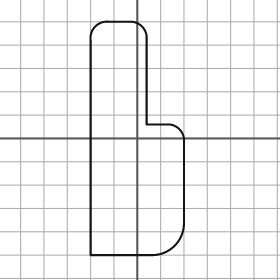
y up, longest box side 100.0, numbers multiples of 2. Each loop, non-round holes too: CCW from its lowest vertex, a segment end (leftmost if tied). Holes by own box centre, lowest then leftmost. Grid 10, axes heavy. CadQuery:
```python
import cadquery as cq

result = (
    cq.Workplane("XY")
    .moveTo(-20.0, -50.0)
    .lineTo(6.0, -50.0)
    .threePointArc((16.0, -46.0), (20.0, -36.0))
    .lineTo(20.0, 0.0)
    .threePointArc((18.0, 4.0), (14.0, 6.0))
    .lineTo(4.0, 6.0)
    .lineTo(4.0, 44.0)
    .threePointArc((2.0, 48.0), (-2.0, 50.0))
    .lineTo(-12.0, 50.0)
    .threePointArc((-18.0, 48.0), (-20.0, 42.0))
    .close()
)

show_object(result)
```